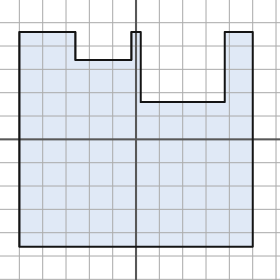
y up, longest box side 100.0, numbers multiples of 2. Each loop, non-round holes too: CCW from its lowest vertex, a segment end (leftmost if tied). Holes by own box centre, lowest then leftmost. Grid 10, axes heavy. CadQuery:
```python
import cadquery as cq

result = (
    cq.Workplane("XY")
    .moveTo(-50.0, -46.0)
    .lineTo(50.0, -46.0)
    .lineTo(50.0, 46.0)
    .lineTo(38.0, 46.0)
    .lineTo(38.0, 16.0)
    .lineTo(2.0, 16.0)
    .lineTo(2.0, 46.0)
    .lineTo(-2.0, 46.0)
    .lineTo(-2.0, 34.0)
    .lineTo(-26.0, 34.0)
    .lineTo(-26.0, 46.0)
    .lineTo(-50.0, 46.0)
    .close()
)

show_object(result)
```